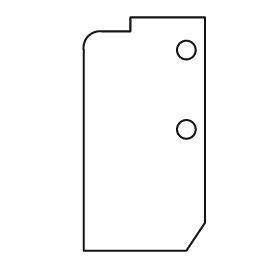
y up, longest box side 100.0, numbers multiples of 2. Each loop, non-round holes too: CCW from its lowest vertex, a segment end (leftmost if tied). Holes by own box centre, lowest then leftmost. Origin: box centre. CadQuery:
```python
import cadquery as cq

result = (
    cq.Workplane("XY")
    .moveTo(-26.0, -50.0)
    .lineTo(18.0, -50.0)
    .lineTo(26.0, -38.0)
    .lineTo(26.0, 50.0)
    .lineTo(-6.0, 50.0)
    .lineTo(-6.0, 44.0)
    .lineTo(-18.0, 44.0)
    .threePointArc((-24.0, 42.0), (-26.0, 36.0))
    .close()
    .moveTo(18.0, 2.0)
    .circle(4.0)
    .moveTo(18.0, 36.0)
    .circle(4.0)
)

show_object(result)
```